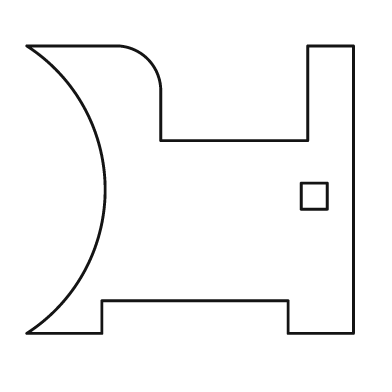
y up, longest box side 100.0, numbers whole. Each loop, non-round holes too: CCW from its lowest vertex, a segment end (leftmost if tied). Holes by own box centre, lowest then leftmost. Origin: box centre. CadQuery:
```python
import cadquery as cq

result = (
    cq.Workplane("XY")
    .moveTo(-50.0, -44.0)
    .lineTo(-27.0, -44.0)
    .lineTo(-27.0, -34.0)
    .lineTo(30.0, -34.0)
    .lineTo(30.0, -44.0)
    .lineTo(50.0, -44.0)
    .lineTo(50.0, 44.0)
    .lineTo(36.0, 44.0)
    .lineTo(36.0, 15.0)
    .lineTo(-9.0, 15.0)
    .lineTo(-9.0, 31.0)
    .threePointArc((-13.0, 40.0), (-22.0, 44.0))
    .lineTo(-50.0, 44.0)
    .threePointArc((-26.0, 0.0), (-50.0, -44.0))
    .close()
    .moveTo(34.0, -6.0)
    .lineTo(42.0, -6.0)
    .lineTo(42.0, 2.0)
    .lineTo(34.0, 2.0)
    .close()
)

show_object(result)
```